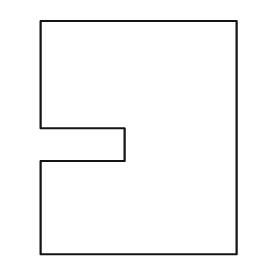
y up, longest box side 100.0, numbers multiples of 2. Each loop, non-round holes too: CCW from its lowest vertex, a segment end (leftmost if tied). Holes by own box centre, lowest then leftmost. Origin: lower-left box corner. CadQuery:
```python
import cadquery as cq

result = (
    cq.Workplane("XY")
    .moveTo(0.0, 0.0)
    .lineTo(84.0, 0.0)
    .lineTo(84.0, 100.0)
    .lineTo(0.0, 100.0)
    .lineTo(0.0, 54.0)
    .lineTo(36.0, 54.0)
    .lineTo(36.0, 40.0)
    .lineTo(0.0, 40.0)
    .close()
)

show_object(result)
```